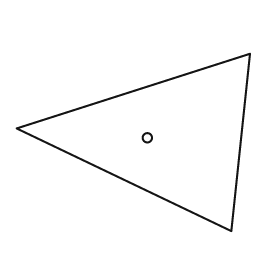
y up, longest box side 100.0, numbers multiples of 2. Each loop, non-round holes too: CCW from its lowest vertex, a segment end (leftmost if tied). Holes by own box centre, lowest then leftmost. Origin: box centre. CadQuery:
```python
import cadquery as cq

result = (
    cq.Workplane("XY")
    .moveTo(42.0, -38.0)
    .lineTo(50.0, 38.0)
    .lineTo(-50.0, 6.0)
    .close()
    .moveTo(6.0, 2.0)
    .circle(2.0)
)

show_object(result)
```